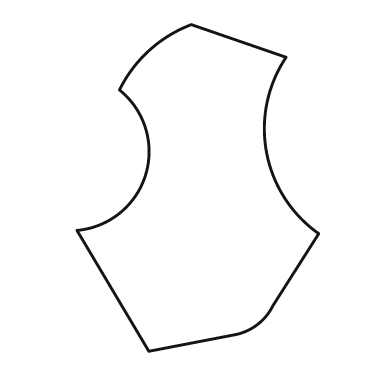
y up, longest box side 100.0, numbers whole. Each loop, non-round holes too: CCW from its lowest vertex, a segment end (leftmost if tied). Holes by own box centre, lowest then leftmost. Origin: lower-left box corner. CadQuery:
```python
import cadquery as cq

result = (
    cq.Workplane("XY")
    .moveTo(22.0, 0.0)
    .lineTo(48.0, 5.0)
    .threePointArc((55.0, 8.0), (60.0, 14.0))
    .lineTo(74.0, 36.0)
    .threePointArc((58.0, 61.0), (64.0, 90.0))
    .lineTo(35.0, 100.0)
    .threePointArc((22.0, 92.0), (13.0, 80.0))
    .threePointArc((21.0, 54.0), (0.0, 37.0))
    .close()
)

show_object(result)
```